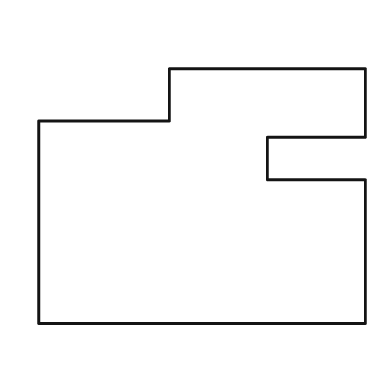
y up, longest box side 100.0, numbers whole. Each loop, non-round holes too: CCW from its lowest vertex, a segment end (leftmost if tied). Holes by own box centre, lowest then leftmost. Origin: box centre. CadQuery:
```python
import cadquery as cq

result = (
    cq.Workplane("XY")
    .moveTo(-50.0, -39.0)
    .lineTo(50.0, -39.0)
    .lineTo(50.0, 5.0)
    .lineTo(20.0, 5.0)
    .lineTo(20.0, 18.0)
    .lineTo(50.0, 18.0)
    .lineTo(50.0, 39.0)
    .lineTo(-10.0, 39.0)
    .lineTo(-10.0, 23.0)
    .lineTo(-50.0, 23.0)
    .close()
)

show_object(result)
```